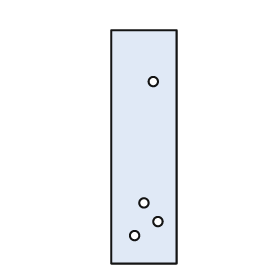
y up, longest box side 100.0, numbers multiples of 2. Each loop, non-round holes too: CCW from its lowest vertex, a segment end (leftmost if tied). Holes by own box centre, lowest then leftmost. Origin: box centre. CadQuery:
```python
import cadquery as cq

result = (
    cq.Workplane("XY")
    .moveTo(-14.0, -50.0)
    .lineTo(14.0, -50.0)
    .lineTo(14.0, 50.0)
    .lineTo(-14.0, 50.0)
    .close()
    .moveTo(-4.0, -38.0)
    .circle(2.0)
    .moveTo(6.0, -32.0)
    .circle(2.0)
    .moveTo(0.0, -24.0)
    .circle(2.0)
    .moveTo(4.0, 28.0)
    .circle(2.0)
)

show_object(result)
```